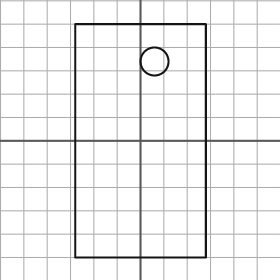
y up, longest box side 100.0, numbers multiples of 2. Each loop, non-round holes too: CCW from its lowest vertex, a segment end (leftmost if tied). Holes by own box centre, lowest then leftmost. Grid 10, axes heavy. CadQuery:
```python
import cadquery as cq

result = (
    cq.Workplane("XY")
    .moveTo(-28.0, -50.0)
    .lineTo(28.0, -50.0)
    .lineTo(28.0, 50.0)
    .lineTo(-28.0, 50.0)
    .close()
    .moveTo(6.0, 34.0)
    .circle(6.0)
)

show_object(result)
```